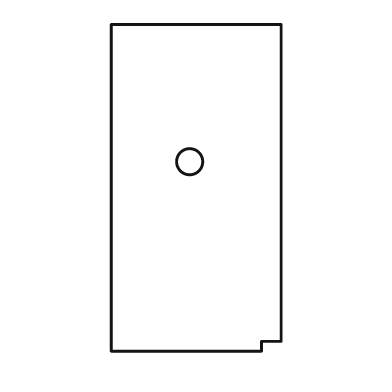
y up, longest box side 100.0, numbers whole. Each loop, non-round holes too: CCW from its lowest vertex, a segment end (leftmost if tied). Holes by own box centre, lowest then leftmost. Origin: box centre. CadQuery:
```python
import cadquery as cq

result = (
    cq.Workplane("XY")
    .moveTo(-26.0, -50.0)
    .lineTo(20.0, -50.0)
    .lineTo(20.0, -47.0)
    .lineTo(26.0, -47.0)
    .lineTo(26.0, 50.0)
    .lineTo(-26.0, 50.0)
    .close()
    .moveTo(-2.0, 8.0)
    .circle(4.0)
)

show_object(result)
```